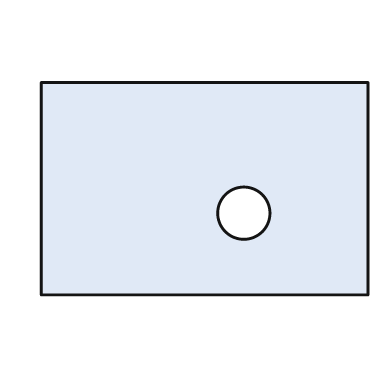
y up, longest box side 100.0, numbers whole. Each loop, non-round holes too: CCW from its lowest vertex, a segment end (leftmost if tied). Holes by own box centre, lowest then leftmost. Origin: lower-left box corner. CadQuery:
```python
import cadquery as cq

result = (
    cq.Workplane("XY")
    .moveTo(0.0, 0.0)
    .lineTo(100.0, 0.0)
    .lineTo(100.0, 65.0)
    .lineTo(0.0, 65.0)
    .close()
    .moveTo(62.0, 25.0)
    .circle(8.0)
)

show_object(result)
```